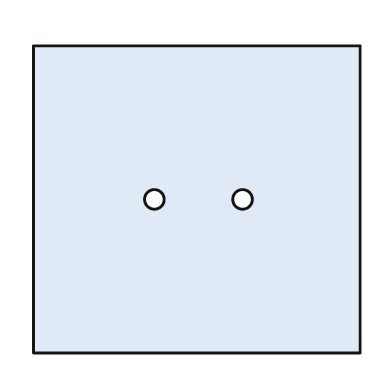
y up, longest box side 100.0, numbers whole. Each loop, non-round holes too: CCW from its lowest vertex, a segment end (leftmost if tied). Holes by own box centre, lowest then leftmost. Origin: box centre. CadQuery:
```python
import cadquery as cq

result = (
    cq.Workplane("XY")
    .moveTo(-50.0, -47.0)
    .lineTo(50.0, -47.0)
    .lineTo(50.0, 47.0)
    .lineTo(-50.0, 47.0)
    .close()
    .moveTo(-13.0, 0.0)
    .circle(3.0)
    .moveTo(14.0, 0.0)
    .circle(3.0)
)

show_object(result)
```